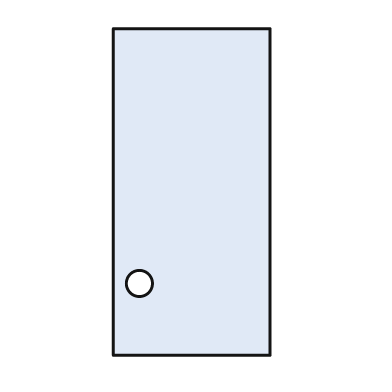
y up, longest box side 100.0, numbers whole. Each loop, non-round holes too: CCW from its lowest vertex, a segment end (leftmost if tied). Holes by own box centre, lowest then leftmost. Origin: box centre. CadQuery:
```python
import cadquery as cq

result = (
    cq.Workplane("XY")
    .moveTo(-24.0, -50.0)
    .lineTo(24.0, -50.0)
    .lineTo(24.0, 50.0)
    .lineTo(-24.0, 50.0)
    .close()
    .moveTo(-16.0, -28.0)
    .circle(4.0)
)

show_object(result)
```